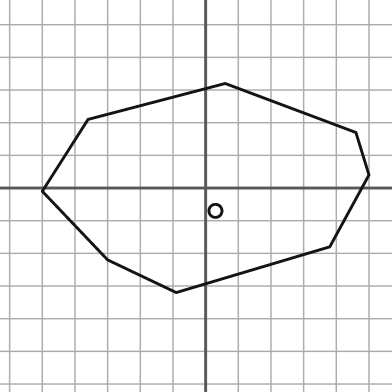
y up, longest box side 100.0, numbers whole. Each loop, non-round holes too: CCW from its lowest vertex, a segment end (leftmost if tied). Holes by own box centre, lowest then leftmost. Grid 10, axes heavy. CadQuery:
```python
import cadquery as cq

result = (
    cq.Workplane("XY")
    .moveTo(-9.0, -32.0)
    .lineTo(38.0, -18.0)
    .lineTo(50.0, 4.0)
    .lineTo(46.0, 17.0)
    .lineTo(6.0, 32.0)
    .lineTo(-36.0, 21.0)
    .lineTo(-50.0, -1.0)
    .lineTo(-30.0, -22.0)
    .close()
    .moveTo(3.0, -7.0)
    .circle(2.0)
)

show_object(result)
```